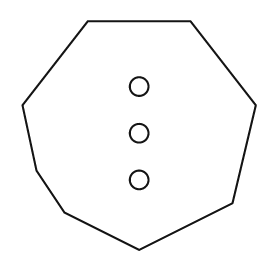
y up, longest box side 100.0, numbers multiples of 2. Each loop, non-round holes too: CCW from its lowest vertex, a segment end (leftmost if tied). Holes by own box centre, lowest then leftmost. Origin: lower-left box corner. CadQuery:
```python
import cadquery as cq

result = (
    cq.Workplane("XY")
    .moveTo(50.0, 0.0)
    .lineTo(90.0, 20.0)
    .lineTo(100.0, 62.0)
    .lineTo(72.0, 98.0)
    .lineTo(28.0, 98.0)
    .lineTo(0.0, 62.0)
    .lineTo(6.0, 34.0)
    .lineTo(18.0, 16.0)
    .close()
    .moveTo(50.0, 30.0)
    .circle(4.0)
    .moveTo(50.0, 50.0)
    .circle(4.0)
    .moveTo(50.0, 70.0)
    .circle(4.0)
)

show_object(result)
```